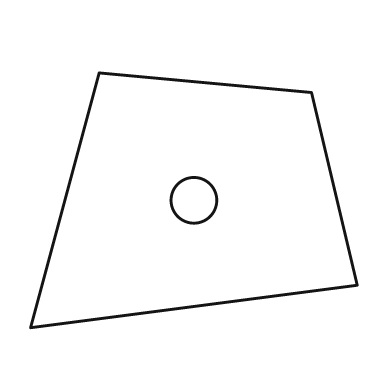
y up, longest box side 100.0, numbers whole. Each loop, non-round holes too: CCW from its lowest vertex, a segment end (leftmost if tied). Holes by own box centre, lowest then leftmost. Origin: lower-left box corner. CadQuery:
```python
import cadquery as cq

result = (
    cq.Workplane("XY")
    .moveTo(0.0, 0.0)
    .lineTo(100.0, 13.0)
    .lineTo(86.0, 72.0)
    .lineTo(21.0, 78.0)
    .close()
    .moveTo(50.0, 39.0)
    .circle(7.0)
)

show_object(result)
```